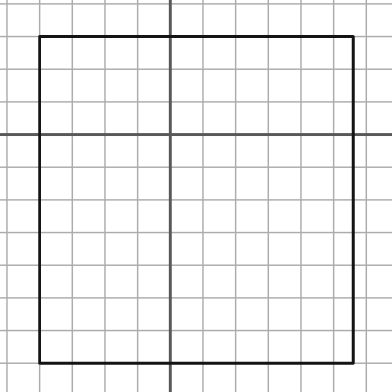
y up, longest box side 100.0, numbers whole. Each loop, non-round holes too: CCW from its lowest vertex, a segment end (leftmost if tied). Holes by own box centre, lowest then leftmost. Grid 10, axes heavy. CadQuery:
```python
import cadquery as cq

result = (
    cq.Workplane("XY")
    .moveTo(-40.0, -70.0)
    .lineTo(56.0, -70.0)
    .lineTo(56.0, 30.0)
    .lineTo(-40.0, 30.0)
    .close()
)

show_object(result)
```